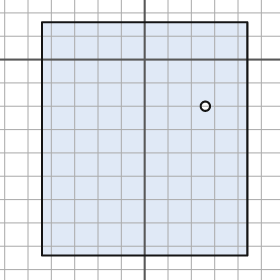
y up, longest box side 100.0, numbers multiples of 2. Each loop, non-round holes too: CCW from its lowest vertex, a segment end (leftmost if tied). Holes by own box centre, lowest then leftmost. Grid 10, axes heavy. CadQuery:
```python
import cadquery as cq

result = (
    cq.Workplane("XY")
    .moveTo(-44.0, -84.0)
    .lineTo(44.0, -84.0)
    .lineTo(44.0, 16.0)
    .lineTo(-44.0, 16.0)
    .close()
    .moveTo(26.0, -20.0)
    .circle(2.0)
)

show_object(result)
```